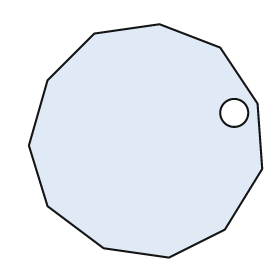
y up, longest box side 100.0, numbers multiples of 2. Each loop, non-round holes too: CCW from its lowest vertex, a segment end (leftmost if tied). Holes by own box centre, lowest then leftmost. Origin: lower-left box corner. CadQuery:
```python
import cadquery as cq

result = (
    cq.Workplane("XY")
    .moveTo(60.0, 0.0)
    .lineTo(84.0, 12.0)
    .lineTo(100.0, 38.0)
    .lineTo(98.0, 66.0)
    .lineTo(82.0, 90.0)
    .lineTo(56.0, 100.0)
    .lineTo(28.0, 96.0)
    .lineTo(8.0, 76.0)
    .lineTo(0.0, 48.0)
    .lineTo(8.0, 22.0)
    .lineTo(32.0, 4.0)
    .close()
    .moveTo(88.0, 62.0)
    .circle(6.0)
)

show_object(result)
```